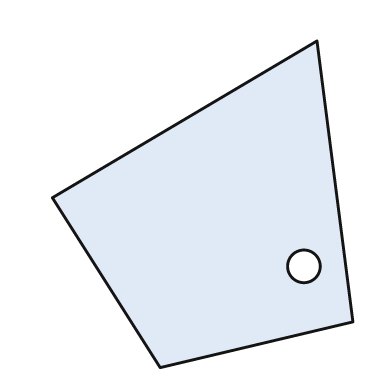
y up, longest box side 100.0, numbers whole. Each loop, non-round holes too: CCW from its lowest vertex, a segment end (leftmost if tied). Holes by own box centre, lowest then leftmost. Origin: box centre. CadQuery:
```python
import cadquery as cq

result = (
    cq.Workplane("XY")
    .moveTo(-13.0, -50.0)
    .lineTo(46.0, -36.0)
    .lineTo(35.0, 50.0)
    .lineTo(-46.0, 2.0)
    .close()
    .moveTo(31.0, -19.0)
    .circle(5.0)
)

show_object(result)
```